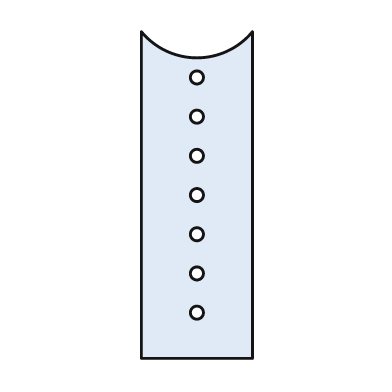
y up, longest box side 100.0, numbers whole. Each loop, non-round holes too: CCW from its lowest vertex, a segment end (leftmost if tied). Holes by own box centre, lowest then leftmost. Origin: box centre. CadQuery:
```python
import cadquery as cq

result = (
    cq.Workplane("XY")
    .moveTo(-17.0, -50.0)
    .lineTo(17.0, -50.0)
    .lineTo(17.0, 50.0)
    .threePointArc((0.0, 42.0), (-17.0, 50.0))
    .close()
    .moveTo(0.0, -36.0)
    .circle(2.0)
    .moveTo(0.0, -24.0)
    .circle(2.0)
    .moveTo(0.0, -12.0)
    .circle(2.0)
    .moveTo(0.0, 0.0)
    .circle(2.0)
    .moveTo(0.0, 12.0)
    .circle(2.0)
    .moveTo(0.0, 24.0)
    .circle(2.0)
    .moveTo(0.0, 36.0)
    .circle(2.0)
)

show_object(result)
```